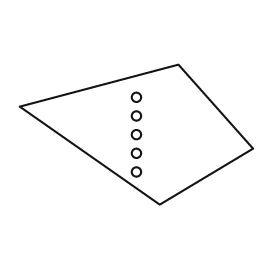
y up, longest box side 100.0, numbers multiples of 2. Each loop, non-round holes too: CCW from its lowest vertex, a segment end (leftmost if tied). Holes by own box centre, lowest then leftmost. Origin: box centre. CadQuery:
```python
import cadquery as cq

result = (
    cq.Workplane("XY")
    .moveTo(10.0, -30.0)
    .lineTo(50.0, -6.0)
    .lineTo(18.0, 30.0)
    .lineTo(-50.0, 12.0)
    .close()
    .moveTo(0.0, -16.0)
    .circle(2.0)
    .moveTo(0.0, -8.0)
    .circle(2.0)
    .moveTo(0.0, 0.0)
    .circle(2.0)
    .moveTo(0.0, 8.0)
    .circle(2.0)
    .moveTo(0.0, 16.0)
    .circle(2.0)
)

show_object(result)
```